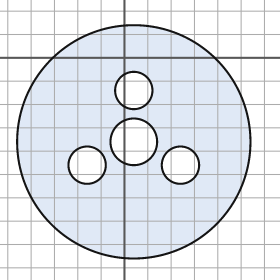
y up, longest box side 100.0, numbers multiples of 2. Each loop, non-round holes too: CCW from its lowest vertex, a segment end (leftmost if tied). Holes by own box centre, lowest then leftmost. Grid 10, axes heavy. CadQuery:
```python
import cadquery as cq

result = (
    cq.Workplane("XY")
    .moveTo(4.0, -36.0)
    .circle(50.0)
    .moveTo(-16.0, -46.0)
    .circle(8.0)
    .moveTo(24.0, -46.0)
    .circle(8.0)
    .moveTo(4.0, -36.0)
    .circle(10.0)
    .moveTo(4.0, -14.0)
    .circle(8.0)
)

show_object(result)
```